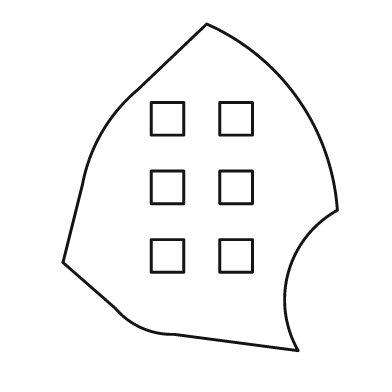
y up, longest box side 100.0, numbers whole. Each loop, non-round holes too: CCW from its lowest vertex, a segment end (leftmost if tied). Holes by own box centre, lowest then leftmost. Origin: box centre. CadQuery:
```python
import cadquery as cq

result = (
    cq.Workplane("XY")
    .moveTo(30.0, -50.0)
    .threePointArc((27.0, -26.0), (42.0, -7.0))
    .threePointArc((30.0, 27.0), (2.0, 50.0))
    .lineTo(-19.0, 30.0)
    .threePointArc((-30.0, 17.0), (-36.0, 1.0))
    .lineTo(-42.0, -23.0)
    .lineTo(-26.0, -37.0)
    .threePointArc((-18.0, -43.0), (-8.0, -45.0))
    .close()
    .moveTo(-15.0, -26.0)
    .lineTo(-5.0, -26.0)
    .lineTo(-5.0, -16.0)
    .lineTo(-15.0, -16.0)
    .close()
    .moveTo(6.0, -26.0)
    .lineTo(16.0, -26.0)
    .lineTo(16.0, -16.0)
    .lineTo(6.0, -16.0)
    .close()
    .moveTo(-15.0, -5.0)
    .lineTo(-5.0, -5.0)
    .lineTo(-5.0, 5.0)
    .lineTo(-15.0, 5.0)
    .close()
    .moveTo(6.0, -5.0)
    .lineTo(16.0, -5.0)
    .lineTo(16.0, 5.0)
    .lineTo(6.0, 5.0)
    .close()
    .moveTo(-15.0, 16.0)
    .lineTo(-5.0, 16.0)
    .lineTo(-5.0, 26.0)
    .lineTo(-15.0, 26.0)
    .close()
    .moveTo(6.0, 16.0)
    .lineTo(16.0, 16.0)
    .lineTo(16.0, 26.0)
    .lineTo(6.0, 26.0)
    .close()
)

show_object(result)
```